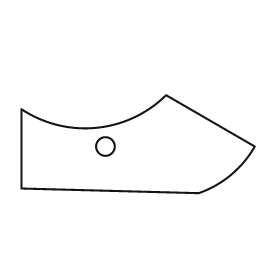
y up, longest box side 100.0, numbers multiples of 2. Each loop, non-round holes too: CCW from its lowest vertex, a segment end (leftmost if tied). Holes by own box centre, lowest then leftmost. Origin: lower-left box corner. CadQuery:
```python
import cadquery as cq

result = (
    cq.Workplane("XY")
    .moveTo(76.0, 0.0)
    .threePointArc((90.0, 8.0), (100.0, 20.0))
    .lineTo(62.0, 42.0)
    .threePointArc((32.0, 28.0), (0.0, 36.0))
    .lineTo(0.0, 2.0)
    .close()
    .moveTo(36.0, 20.0)
    .circle(4.0)
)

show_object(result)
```